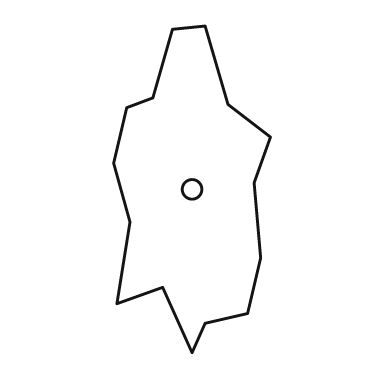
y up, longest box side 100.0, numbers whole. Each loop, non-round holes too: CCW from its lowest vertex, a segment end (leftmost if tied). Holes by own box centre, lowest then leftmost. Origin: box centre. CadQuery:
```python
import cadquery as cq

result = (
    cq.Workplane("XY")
    .moveTo(0.0, -50.0)
    .lineTo(4.0, -41.0)
    .lineTo(17.0, -38.0)
    .lineTo(21.0, -21.0)
    .lineTo(19.0, 2.0)
    .lineTo(24.0, 16.0)
    .lineTo(11.0, 26.0)
    .lineTo(4.0, 50.0)
    .lineTo(-6.0, 49.0)
    .lineTo(-12.0, 28.0)
    .lineTo(-20.0, 25.0)
    .lineTo(-24.0, 8.0)
    .lineTo(-19.0, -10.0)
    .lineTo(-23.0, -35.0)
    .lineTo(-9.0, -30.0)
    .close()
    .moveTo(0.0, 0.0)
    .circle(3.0)
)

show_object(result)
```